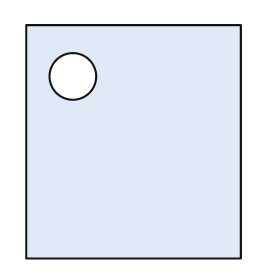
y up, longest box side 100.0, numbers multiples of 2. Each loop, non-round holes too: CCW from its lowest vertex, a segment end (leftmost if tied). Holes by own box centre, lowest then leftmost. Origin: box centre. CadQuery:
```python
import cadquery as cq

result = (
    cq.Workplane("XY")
    .moveTo(-46.0, -50.0)
    .lineTo(46.0, -50.0)
    .lineTo(46.0, 50.0)
    .lineTo(-46.0, 50.0)
    .close()
    .moveTo(-26.0, 28.0)
    .circle(10.0)
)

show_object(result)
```